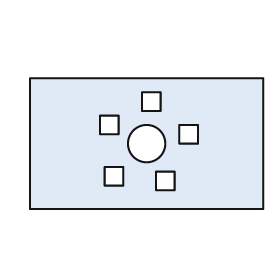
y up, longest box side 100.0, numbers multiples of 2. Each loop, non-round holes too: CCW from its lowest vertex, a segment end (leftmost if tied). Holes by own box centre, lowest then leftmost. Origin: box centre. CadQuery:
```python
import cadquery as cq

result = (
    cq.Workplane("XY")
    .moveTo(-50.0, -28.0)
    .lineTo(50.0, -28.0)
    .lineTo(50.0, 28.0)
    .lineTo(-50.0, 28.0)
    .close()
    .moveTo(4.0, -20.0)
    .lineTo(12.0, -20.0)
    .lineTo(12.0, -12.0)
    .lineTo(4.0, -12.0)
    .close()
    .moveTo(-18.0, -18.0)
    .lineTo(-10.0, -18.0)
    .lineTo(-10.0, -10.0)
    .lineTo(-18.0, -10.0)
    .close()
    .moveTo(0.0, 0.0)
    .circle(8.0)
    .moveTo(14.0, 0.0)
    .lineTo(22.0, 0.0)
    .lineTo(22.0, 8.0)
    .lineTo(14.0, 8.0)
    .close()
    .moveTo(-20.0, 4.0)
    .lineTo(-12.0, 4.0)
    .lineTo(-12.0, 12.0)
    .lineTo(-20.0, 12.0)
    .close()
    .moveTo(-2.0, 14.0)
    .lineTo(6.0, 14.0)
    .lineTo(6.0, 22.0)
    .lineTo(-2.0, 22.0)
    .close()
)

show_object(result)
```